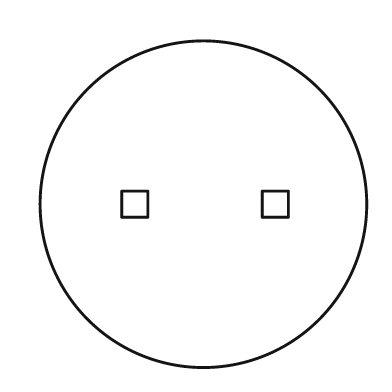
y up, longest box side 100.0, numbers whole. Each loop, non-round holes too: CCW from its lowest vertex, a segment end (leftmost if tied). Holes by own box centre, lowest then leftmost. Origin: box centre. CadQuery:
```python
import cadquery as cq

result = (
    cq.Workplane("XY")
    .moveTo(0.0, 0.0)
    .circle(50.0)
    .moveTo(-25.0, -4.0)
    .lineTo(-17.0, -4.0)
    .lineTo(-17.0, 4.0)
    .lineTo(-25.0, 4.0)
    .close()
    .moveTo(18.0, -4.0)
    .lineTo(26.0, -4.0)
    .lineTo(26.0, 4.0)
    .lineTo(18.0, 4.0)
    .close()
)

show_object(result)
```